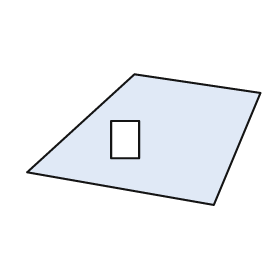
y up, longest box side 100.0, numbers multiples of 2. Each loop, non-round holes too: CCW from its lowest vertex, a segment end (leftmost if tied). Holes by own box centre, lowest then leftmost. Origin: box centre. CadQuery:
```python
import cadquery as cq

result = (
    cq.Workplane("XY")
    .moveTo(30.0, -28.0)
    .lineTo(50.0, 20.0)
    .lineTo(-4.0, 28.0)
    .lineTo(-50.0, -14.0)
    .close()
    .moveTo(-14.0, -8.0)
    .lineTo(-2.0, -8.0)
    .lineTo(-2.0, 8.0)
    .lineTo(-14.0, 8.0)
    .close()
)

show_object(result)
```